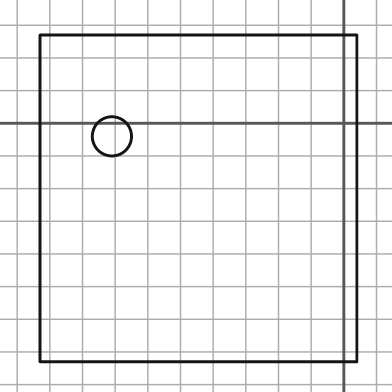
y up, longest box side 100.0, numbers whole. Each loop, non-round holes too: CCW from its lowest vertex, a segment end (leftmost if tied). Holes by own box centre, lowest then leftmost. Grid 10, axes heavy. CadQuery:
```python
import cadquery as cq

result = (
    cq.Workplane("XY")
    .moveTo(-93.0, -73.0)
    .lineTo(4.0, -73.0)
    .lineTo(4.0, 27.0)
    .lineTo(-93.0, 27.0)
    .close()
    .moveTo(-71.0, -4.0)
    .circle(6.0)
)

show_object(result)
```